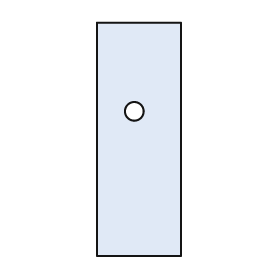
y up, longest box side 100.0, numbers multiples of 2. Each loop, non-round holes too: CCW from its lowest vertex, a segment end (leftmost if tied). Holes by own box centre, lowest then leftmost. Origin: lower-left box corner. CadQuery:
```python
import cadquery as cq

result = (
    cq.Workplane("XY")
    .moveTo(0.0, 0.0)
    .lineTo(36.0, 0.0)
    .lineTo(36.0, 100.0)
    .lineTo(0.0, 100.0)
    .close()
    .moveTo(16.0, 62.0)
    .circle(4.0)
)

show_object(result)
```